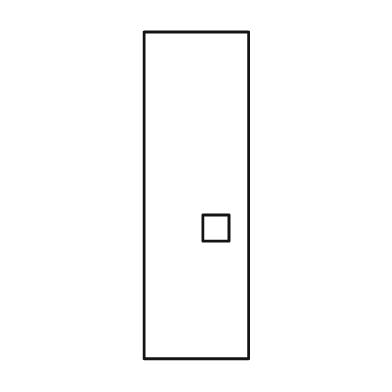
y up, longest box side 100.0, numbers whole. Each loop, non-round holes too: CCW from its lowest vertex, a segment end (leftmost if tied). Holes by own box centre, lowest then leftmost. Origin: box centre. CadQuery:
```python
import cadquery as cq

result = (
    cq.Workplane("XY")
    .moveTo(-16.0, -50.0)
    .lineTo(16.0, -50.0)
    .lineTo(16.0, 50.0)
    .lineTo(-16.0, 50.0)
    .close()
    .moveTo(2.0, -14.0)
    .lineTo(10.0, -14.0)
    .lineTo(10.0, -6.0)
    .lineTo(2.0, -6.0)
    .close()
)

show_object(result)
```